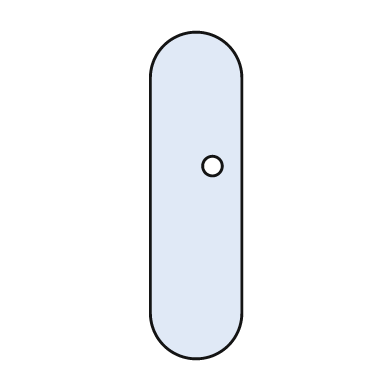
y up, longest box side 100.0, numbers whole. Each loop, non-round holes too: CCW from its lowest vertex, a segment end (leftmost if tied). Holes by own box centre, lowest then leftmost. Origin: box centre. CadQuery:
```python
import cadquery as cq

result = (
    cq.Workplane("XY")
    .moveTo(-14.0, -36.0)
    .threePointArc((0.0, -50.0), (14.0, -36.0))
    .lineTo(14.0, 36.0)
    .threePointArc((0.0, 50.0), (-14.0, 36.0))
    .close()
    .moveTo(5.0, 9.0)
    .circle(3.0)
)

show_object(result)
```